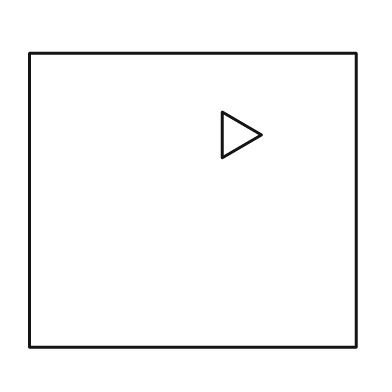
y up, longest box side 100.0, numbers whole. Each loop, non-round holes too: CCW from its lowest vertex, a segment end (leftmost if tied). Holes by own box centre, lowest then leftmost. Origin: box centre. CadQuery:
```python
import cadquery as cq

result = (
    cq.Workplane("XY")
    .moveTo(-50.0, -45.0)
    .lineTo(50.0, -45.0)
    .lineTo(50.0, 45.0)
    .lineTo(-50.0, 45.0)
    .close()
    .moveTo(9.0, 13.0)
    .lineTo(21.0, 20.0)
    .lineTo(9.0, 27.0)
    .close()
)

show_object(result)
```